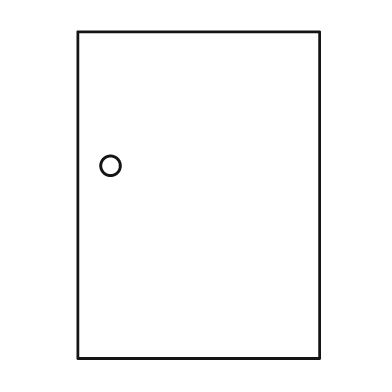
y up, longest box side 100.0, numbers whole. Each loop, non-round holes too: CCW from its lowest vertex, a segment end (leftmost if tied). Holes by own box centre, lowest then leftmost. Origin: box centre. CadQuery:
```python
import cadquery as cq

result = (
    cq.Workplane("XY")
    .moveTo(-37.0, -50.0)
    .lineTo(37.0, -50.0)
    .lineTo(37.0, 50.0)
    .lineTo(-37.0, 50.0)
    .close()
    .moveTo(-27.0, 9.0)
    .circle(3.0)
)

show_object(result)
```